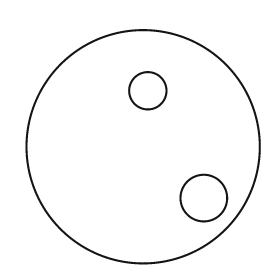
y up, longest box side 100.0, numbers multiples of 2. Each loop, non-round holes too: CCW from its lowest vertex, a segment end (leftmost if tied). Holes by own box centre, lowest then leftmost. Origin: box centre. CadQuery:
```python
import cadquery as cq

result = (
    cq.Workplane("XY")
    .moveTo(0.0, 0.0)
    .circle(50.0)
    .moveTo(26.0, -22.0)
    .circle(10.0)
    .moveTo(2.0, 24.0)
    .circle(8.0)
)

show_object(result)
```